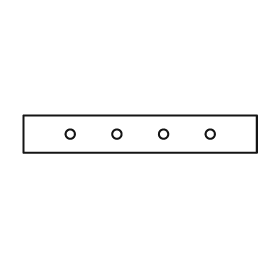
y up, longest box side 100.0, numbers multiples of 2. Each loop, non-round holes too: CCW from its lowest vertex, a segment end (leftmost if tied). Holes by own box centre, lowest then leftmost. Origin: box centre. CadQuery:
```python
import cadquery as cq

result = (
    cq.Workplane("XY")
    .moveTo(-50.0, -8.0)
    .lineTo(50.0, -8.0)
    .lineTo(50.0, 8.0)
    .lineTo(-50.0, 8.0)
    .close()
    .moveTo(-30.0, 0.0)
    .circle(2.0)
    .moveTo(-10.0, 0.0)
    .circle(2.0)
    .moveTo(10.0, 0.0)
    .circle(2.0)
    .moveTo(30.0, 0.0)
    .circle(2.0)
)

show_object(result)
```